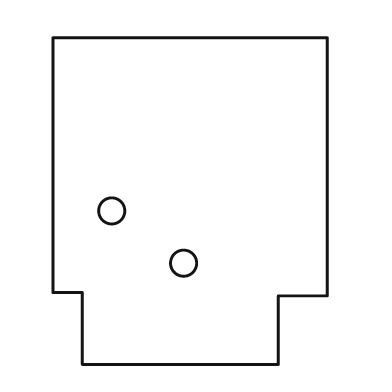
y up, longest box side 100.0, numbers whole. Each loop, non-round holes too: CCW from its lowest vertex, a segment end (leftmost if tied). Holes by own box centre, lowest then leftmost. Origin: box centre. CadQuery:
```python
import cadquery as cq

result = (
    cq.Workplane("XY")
    .moveTo(-33.0, -50.0)
    .lineTo(27.0, -50.0)
    .lineTo(27.0, -29.0)
    .lineTo(42.0, -29.0)
    .lineTo(42.0, 50.0)
    .lineTo(-42.0, 50.0)
    .lineTo(-42.0, -28.0)
    .lineTo(-33.0, -28.0)
    .close()
    .moveTo(-2.0, -19.0)
    .circle(4.0)
    .moveTo(-24.0, -3.0)
    .circle(4.0)
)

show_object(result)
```